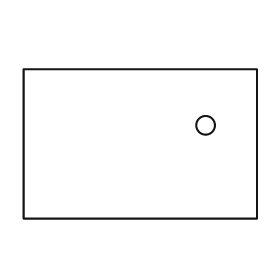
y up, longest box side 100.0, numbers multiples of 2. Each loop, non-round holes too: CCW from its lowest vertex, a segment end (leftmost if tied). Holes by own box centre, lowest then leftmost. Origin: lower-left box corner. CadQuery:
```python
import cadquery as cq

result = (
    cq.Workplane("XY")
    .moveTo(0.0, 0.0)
    .lineTo(100.0, 0.0)
    .lineTo(100.0, 64.0)
    .lineTo(0.0, 64.0)
    .close()
    .moveTo(78.0, 40.0)
    .circle(4.0)
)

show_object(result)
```